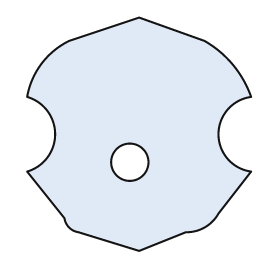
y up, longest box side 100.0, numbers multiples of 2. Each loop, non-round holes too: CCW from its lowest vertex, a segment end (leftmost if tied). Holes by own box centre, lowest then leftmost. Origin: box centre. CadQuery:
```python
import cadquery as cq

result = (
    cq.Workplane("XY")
    .moveTo(0.0, -50.0)
    .lineTo(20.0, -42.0)
    .threePointArc((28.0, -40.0), (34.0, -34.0))
    .lineTo(48.0, -16.0)
    .threePointArc((34.0, 0.0), (48.0, 16.0))
    .threePointArc((40.0, 30.0), (28.0, 40.0))
    .lineTo(0.0, 50.0)
    .lineTo(-30.0, 40.0)
    .threePointArc((-42.0, 30.0), (-48.0, 16.0))
    .threePointArc((-36.0, 0.0), (-48.0, -16.0))
    .lineTo(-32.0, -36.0)
    .threePointArc((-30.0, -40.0), (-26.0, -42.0))
    .close()
    .moveTo(-4.0, -12.0)
    .circle(8.0)
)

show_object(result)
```